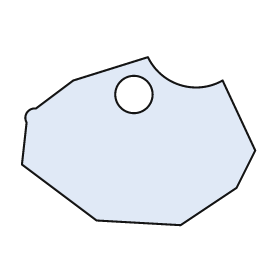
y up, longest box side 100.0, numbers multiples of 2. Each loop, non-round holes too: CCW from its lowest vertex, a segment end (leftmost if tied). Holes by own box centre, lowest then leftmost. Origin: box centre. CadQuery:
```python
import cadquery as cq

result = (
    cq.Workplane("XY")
    .moveTo(18.0, -36.0)
    .lineTo(42.0, -20.0)
    .lineTo(50.0, -4.0)
    .lineTo(36.0, 26.0)
    .threePointArc((18.0, 24.0), (4.0, 36.0))
    .lineTo(-28.0, 26.0)
    .lineTo(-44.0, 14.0)
    .threePointArc((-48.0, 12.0), (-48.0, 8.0))
    .lineTo(-50.0, -10.0)
    .lineTo(-18.0, -34.0)
    .close()
    .moveTo(-2.0, 20.0)
    .circle(8.0)
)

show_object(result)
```